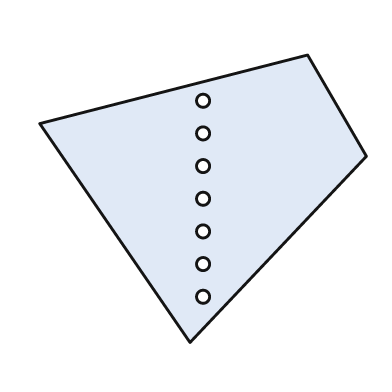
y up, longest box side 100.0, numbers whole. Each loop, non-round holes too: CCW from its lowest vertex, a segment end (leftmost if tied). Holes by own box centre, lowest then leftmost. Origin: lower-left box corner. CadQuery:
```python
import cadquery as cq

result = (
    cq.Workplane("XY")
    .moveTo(46.0, 0.0)
    .lineTo(100.0, 57.0)
    .lineTo(82.0, 88.0)
    .lineTo(0.0, 67.0)
    .close()
    .moveTo(50.0, 14.0)
    .circle(2.0)
    .moveTo(50.0, 24.0)
    .circle(2.0)
    .moveTo(50.0, 34.0)
    .circle(2.0)
    .moveTo(50.0, 44.0)
    .circle(2.0)
    .moveTo(50.0, 54.0)
    .circle(2.0)
    .moveTo(50.0, 64.0)
    .circle(2.0)
    .moveTo(50.0, 74.0)
    .circle(2.0)
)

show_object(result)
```